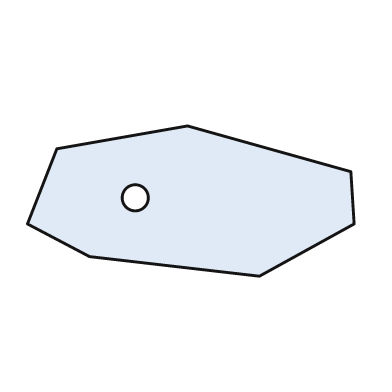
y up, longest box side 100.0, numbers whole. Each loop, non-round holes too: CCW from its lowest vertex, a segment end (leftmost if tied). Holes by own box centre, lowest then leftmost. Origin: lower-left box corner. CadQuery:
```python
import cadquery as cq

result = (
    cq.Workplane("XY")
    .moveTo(71.0, 0.0)
    .lineTo(100.0, 16.0)
    .lineTo(99.0, 32.0)
    .lineTo(49.0, 46.0)
    .lineTo(9.0, 39.0)
    .lineTo(0.0, 16.0)
    .lineTo(19.0, 6.0)
    .close()
    .moveTo(33.0, 24.0)
    .circle(4.0)
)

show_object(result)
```